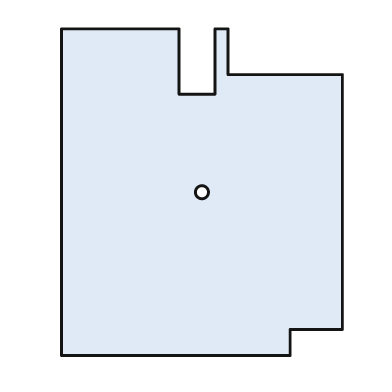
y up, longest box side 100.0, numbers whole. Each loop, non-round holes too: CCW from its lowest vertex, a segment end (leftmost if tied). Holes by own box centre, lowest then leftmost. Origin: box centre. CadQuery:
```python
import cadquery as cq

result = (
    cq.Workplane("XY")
    .moveTo(-43.0, -50.0)
    .lineTo(27.0, -50.0)
    .lineTo(27.0, -42.0)
    .lineTo(43.0, -42.0)
    .lineTo(43.0, 36.0)
    .lineTo(8.0, 36.0)
    .lineTo(8.0, 50.0)
    .lineTo(4.0, 50.0)
    .lineTo(4.0, 30.0)
    .lineTo(-7.0, 30.0)
    .lineTo(-7.0, 50.0)
    .lineTo(-43.0, 50.0)
    .close()
    .moveTo(0.0, 0.0)
    .circle(2.0)
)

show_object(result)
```